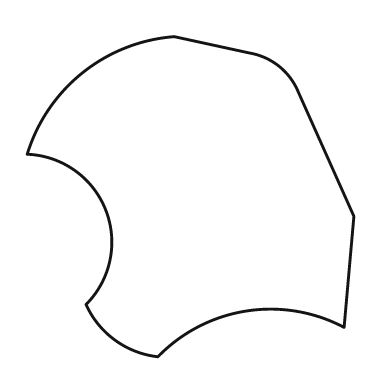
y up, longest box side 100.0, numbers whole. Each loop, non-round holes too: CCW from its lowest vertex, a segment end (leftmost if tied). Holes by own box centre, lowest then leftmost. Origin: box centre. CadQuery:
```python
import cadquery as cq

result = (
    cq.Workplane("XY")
    .moveTo(-10.0, -49.0)
    .threePointArc((17.0, -35.0), (47.0, -40.0))
    .lineTo(50.0, -6.0)
    .lineTo(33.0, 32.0)
    .threePointArc((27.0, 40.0), (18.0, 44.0))
    .lineTo(-5.0, 49.0)
    .threePointArc((-33.0, 38.0), (-50.0, 13.0))
    .threePointArc((-26.0, -4.0), (-32.0, -33.0))
    .threePointArc((-23.0, -44.0), (-10.0, -49.0))
    .close()
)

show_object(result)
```